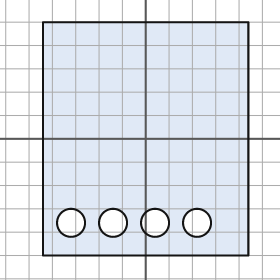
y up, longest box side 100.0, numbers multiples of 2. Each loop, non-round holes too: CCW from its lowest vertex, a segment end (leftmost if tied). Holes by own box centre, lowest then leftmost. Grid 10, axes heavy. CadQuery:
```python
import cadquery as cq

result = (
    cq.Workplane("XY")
    .moveTo(-44.0, -50.0)
    .lineTo(44.0, -50.0)
    .lineTo(44.0, 50.0)
    .lineTo(-44.0, 50.0)
    .close()
    .moveTo(-32.0, -36.0)
    .circle(6.0)
    .moveTo(-14.0, -36.0)
    .circle(6.0)
    .moveTo(4.0, -36.0)
    .circle(6.0)
    .moveTo(22.0, -36.0)
    .circle(6.0)
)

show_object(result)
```